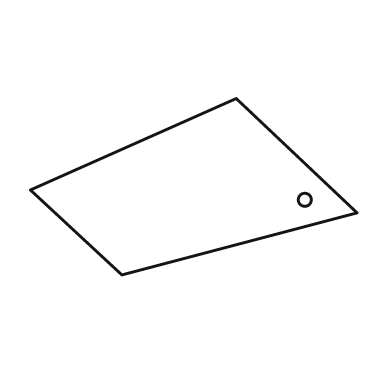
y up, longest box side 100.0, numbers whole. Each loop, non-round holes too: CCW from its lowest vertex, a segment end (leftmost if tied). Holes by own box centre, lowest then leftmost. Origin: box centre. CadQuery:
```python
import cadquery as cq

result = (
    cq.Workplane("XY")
    .moveTo(-22.0, -27.0)
    .lineTo(50.0, -8.0)
    .lineTo(13.0, 27.0)
    .lineTo(-50.0, -1.0)
    .close()
    .moveTo(34.0, -4.0)
    .circle(2.0)
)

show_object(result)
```